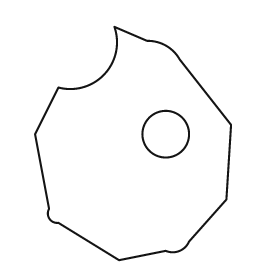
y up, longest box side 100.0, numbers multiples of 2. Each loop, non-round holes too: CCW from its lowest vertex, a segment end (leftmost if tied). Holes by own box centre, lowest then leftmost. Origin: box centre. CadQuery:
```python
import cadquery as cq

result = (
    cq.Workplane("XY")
    .moveTo(-6.0, -50.0)
    .lineTo(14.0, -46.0)
    .threePointArc((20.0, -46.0), (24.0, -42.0))
    .lineTo(40.0, -24.0)
    .lineTo(42.0, 8.0)
    .lineTo(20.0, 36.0)
    .threePointArc((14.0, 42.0), (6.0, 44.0))
    .lineTo(-8.0, 50.0)
    .threePointArc((-12.0, 30.0), (-32.0, 24.0))
    .lineTo(-42.0, 4.0)
    .lineTo(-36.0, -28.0)
    .threePointArc((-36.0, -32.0), (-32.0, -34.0))
    .close()
    .moveTo(14.0, 4.0)
    .circle(10.0)
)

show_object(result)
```